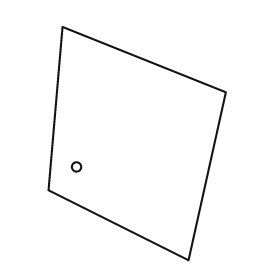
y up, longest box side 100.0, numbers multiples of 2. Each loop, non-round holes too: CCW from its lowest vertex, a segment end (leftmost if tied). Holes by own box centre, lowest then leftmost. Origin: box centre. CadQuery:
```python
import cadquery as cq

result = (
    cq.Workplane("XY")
    .moveTo(22.0, -50.0)
    .lineTo(38.0, 22.0)
    .lineTo(-32.0, 50.0)
    .lineTo(-38.0, -20.0)
    .close()
    .moveTo(-26.0, -10.0)
    .circle(2.0)
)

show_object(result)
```